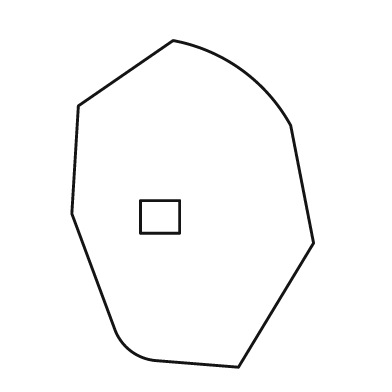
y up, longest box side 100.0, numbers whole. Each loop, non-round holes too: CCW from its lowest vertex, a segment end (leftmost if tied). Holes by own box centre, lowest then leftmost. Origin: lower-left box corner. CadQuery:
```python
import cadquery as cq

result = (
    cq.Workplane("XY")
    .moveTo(51.0, 0.0)
    .lineTo(74.0, 38.0)
    .lineTo(67.0, 74.0)
    .threePointArc((52.0, 91.0), (31.0, 100.0))
    .lineTo(2.0, 80.0)
    .lineTo(0.0, 47.0)
    .lineTo(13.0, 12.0)
    .threePointArc((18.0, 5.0), (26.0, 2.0))
    .close()
    .moveTo(21.0, 41.0)
    .lineTo(33.0, 41.0)
    .lineTo(33.0, 51.0)
    .lineTo(21.0, 51.0)
    .close()
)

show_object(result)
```